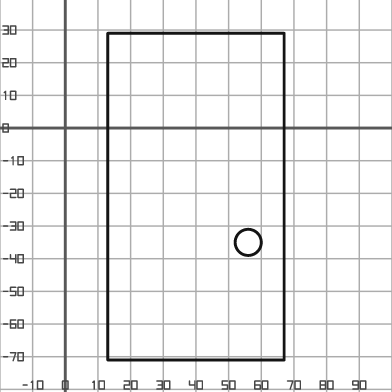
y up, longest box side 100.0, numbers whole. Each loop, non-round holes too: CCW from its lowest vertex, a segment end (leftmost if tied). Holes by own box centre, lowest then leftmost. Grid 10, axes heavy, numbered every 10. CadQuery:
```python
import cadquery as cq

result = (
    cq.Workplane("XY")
    .moveTo(13.0, -71.0)
    .lineTo(67.0, -71.0)
    .lineTo(67.0, 29.0)
    .lineTo(13.0, 29.0)
    .close()
    .moveTo(56.0, -35.0)
    .circle(4.0)
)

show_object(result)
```